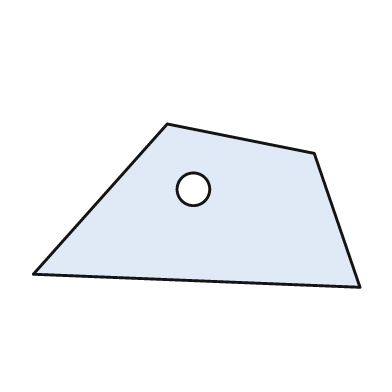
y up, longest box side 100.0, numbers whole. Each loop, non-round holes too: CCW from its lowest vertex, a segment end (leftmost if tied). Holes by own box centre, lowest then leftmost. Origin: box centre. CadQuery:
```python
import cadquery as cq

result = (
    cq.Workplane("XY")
    .moveTo(50.0, -25.0)
    .lineTo(36.0, 16.0)
    .lineTo(-9.0, 25.0)
    .lineTo(-50.0, -21.0)
    .close()
    .moveTo(-1.0, 5.0)
    .circle(5.0)
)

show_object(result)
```